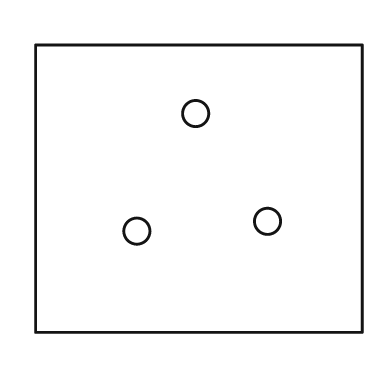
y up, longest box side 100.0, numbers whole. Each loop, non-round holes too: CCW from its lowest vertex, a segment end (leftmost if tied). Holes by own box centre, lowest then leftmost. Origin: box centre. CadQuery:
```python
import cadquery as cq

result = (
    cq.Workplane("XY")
    .moveTo(-50.0, -44.0)
    .lineTo(50.0, -44.0)
    .lineTo(50.0, 44.0)
    .lineTo(-50.0, 44.0)
    .close()
    .moveTo(-19.0, -13.0)
    .circle(4.0)
    .moveTo(21.0, -10.0)
    .circle(4.0)
    .moveTo(-1.0, 23.0)
    .circle(4.0)
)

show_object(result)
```